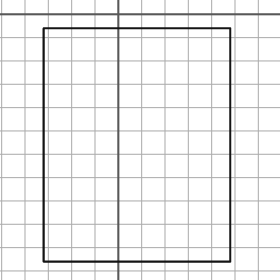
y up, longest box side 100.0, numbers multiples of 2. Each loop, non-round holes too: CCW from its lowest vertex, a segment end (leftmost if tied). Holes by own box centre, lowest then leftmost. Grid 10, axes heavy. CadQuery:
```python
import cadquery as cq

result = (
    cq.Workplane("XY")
    .moveTo(-32.0, -106.0)
    .lineTo(48.0, -106.0)
    .lineTo(48.0, -6.0)
    .lineTo(-32.0, -6.0)
    .close()
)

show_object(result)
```